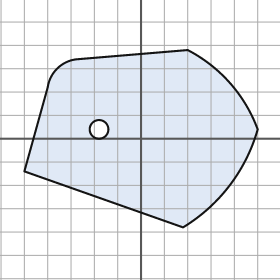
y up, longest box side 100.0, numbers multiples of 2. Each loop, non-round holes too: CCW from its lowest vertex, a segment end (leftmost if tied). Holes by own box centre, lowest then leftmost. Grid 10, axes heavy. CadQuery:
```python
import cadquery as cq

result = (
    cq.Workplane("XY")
    .moveTo(18.0, -38.0)
    .threePointArc((38.0, -20.0), (50.0, 4.0))
    .threePointArc((38.0, 24.0), (20.0, 38.0))
    .lineTo(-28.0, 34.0)
    .threePointArc((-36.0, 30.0), (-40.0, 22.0))
    .lineTo(-50.0, -14.0)
    .close()
    .moveTo(-18.0, 4.0)
    .circle(4.0)
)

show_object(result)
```